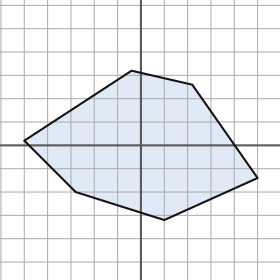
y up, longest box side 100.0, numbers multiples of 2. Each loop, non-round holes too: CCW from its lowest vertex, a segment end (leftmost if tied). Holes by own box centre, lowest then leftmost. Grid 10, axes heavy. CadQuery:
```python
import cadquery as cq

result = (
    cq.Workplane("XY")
    .moveTo(10.0, -32.0)
    .lineTo(50.0, -14.0)
    .lineTo(22.0, 26.0)
    .lineTo(-4.0, 32.0)
    .lineTo(-50.0, 2.0)
    .lineTo(-28.0, -20.0)
    .close()
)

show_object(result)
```